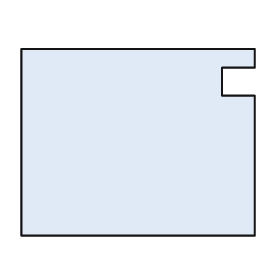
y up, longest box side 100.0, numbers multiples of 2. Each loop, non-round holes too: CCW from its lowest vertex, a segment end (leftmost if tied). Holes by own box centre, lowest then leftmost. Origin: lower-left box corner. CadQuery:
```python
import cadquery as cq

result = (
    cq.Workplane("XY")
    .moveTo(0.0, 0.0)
    .lineTo(100.0, 0.0)
    .lineTo(100.0, 60.0)
    .lineTo(86.0, 60.0)
    .lineTo(86.0, 72.0)
    .lineTo(100.0, 72.0)
    .lineTo(100.0, 80.0)
    .lineTo(0.0, 80.0)
    .close()
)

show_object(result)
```